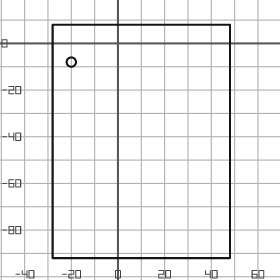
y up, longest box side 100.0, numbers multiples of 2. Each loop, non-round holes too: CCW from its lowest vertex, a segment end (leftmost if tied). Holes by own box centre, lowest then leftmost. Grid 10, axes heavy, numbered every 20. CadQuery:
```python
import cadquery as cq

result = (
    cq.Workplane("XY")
    .moveTo(-28.0, -92.0)
    .lineTo(48.0, -92.0)
    .lineTo(48.0, 8.0)
    .lineTo(-28.0, 8.0)
    .close()
    .moveTo(-20.0, -8.0)
    .circle(2.0)
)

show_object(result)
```